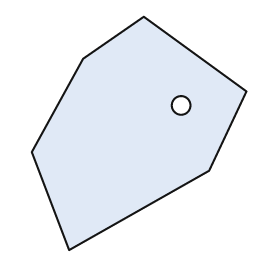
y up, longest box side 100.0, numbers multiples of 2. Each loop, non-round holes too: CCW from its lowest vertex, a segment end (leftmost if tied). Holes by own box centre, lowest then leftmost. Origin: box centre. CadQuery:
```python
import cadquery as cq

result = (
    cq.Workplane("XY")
    .moveTo(-30.0, -50.0)
    .lineTo(30.0, -16.0)
    .lineTo(46.0, 18.0)
    .lineTo(2.0, 50.0)
    .lineTo(-24.0, 32.0)
    .lineTo(-46.0, -8.0)
    .close()
    .moveTo(18.0, 12.0)
    .circle(4.0)
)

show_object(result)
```